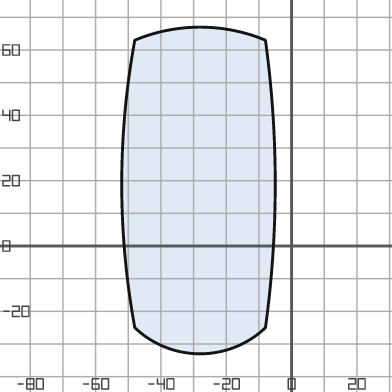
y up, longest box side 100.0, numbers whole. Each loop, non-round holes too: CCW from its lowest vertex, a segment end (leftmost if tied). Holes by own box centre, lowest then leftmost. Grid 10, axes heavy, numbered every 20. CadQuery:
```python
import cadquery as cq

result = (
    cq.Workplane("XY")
    .moveTo(-48.0, -25.0)
    .threePointArc((-28.0, -33.0), (-8.0, -25.0))
    .threePointArc((-5.0, 19.0), (-8.0, 63.0))
    .threePointArc((-28.0, 67.0), (-48.0, 63.0))
    .threePointArc((-52.0, 19.0), (-48.0, -25.0))
    .close()
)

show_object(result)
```